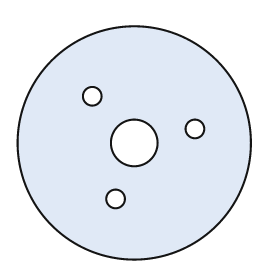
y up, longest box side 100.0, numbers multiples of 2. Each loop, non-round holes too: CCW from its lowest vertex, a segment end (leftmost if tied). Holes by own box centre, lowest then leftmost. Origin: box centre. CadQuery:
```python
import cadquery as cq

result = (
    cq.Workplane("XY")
    .moveTo(0.0, 0.0)
    .circle(50.0)
    .moveTo(-8.0, -24.0)
    .circle(4.0)
    .moveTo(0.0, 0.0)
    .circle(10.0)
    .moveTo(26.0, 6.0)
    .circle(4.0)
    .moveTo(-18.0, 20.0)
    .circle(4.0)
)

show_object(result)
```